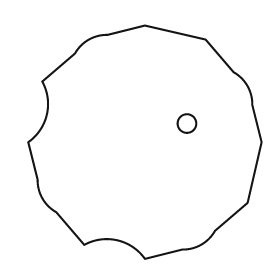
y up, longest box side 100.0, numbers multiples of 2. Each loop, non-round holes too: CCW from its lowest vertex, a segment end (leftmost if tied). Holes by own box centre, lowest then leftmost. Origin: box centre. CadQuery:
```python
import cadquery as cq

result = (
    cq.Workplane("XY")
    .moveTo(0.0, -50.0)
    .lineTo(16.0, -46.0)
    .threePointArc((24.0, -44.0), (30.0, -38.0))
    .lineTo(44.0, -26.0)
    .lineTo(50.0, 0.0)
    .lineTo(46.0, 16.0)
    .threePointArc((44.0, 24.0), (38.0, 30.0))
    .lineTo(26.0, 44.0)
    .lineTo(0.0, 50.0)
    .lineTo(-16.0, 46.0)
    .threePointArc((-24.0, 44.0), (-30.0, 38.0))
    .lineTo(-44.0, 26.0)
    .threePointArc((-42.0, 12.0), (-50.0, 0.0))
    .lineTo(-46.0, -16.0)
    .threePointArc((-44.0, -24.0), (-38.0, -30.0))
    .lineTo(-26.0, -44.0)
    .threePointArc((-12.0, -42.0), (0.0, -50.0))
    .close()
    .moveTo(18.0, 8.0)
    .circle(4.0)
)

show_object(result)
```